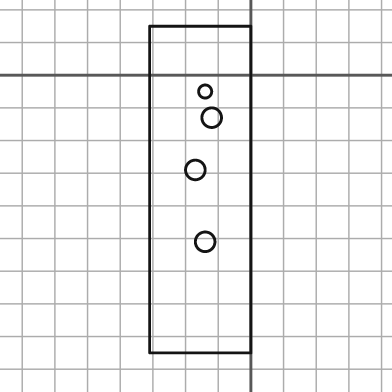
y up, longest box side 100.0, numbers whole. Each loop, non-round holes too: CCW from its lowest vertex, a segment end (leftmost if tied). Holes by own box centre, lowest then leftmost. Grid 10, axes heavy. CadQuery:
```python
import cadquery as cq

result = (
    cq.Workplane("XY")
    .moveTo(-31.0, -85.0)
    .lineTo(0.0, -85.0)
    .lineTo(0.0, 15.0)
    .lineTo(-31.0, 15.0)
    .close()
    .moveTo(-14.0, -51.0)
    .circle(3.0)
    .moveTo(-17.0, -29.0)
    .circle(3.0)
    .moveTo(-12.0, -13.0)
    .circle(3.0)
    .moveTo(-14.0, -5.0)
    .circle(2.0)
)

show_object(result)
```